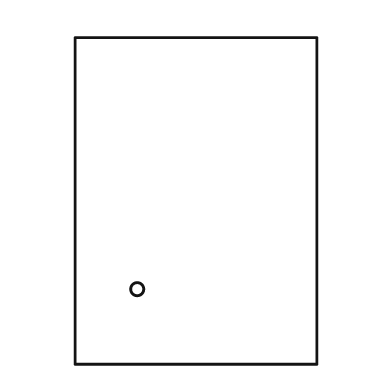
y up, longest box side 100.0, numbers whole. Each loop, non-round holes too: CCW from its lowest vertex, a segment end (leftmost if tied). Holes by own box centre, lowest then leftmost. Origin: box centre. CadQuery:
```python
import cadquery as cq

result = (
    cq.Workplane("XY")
    .moveTo(-37.0, -50.0)
    .lineTo(37.0, -50.0)
    .lineTo(37.0, 50.0)
    .lineTo(-37.0, 50.0)
    .close()
    .moveTo(-18.0, -27.0)
    .circle(2.0)
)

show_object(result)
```